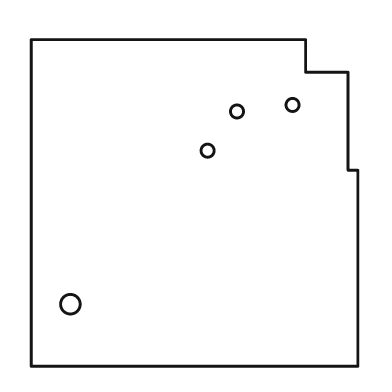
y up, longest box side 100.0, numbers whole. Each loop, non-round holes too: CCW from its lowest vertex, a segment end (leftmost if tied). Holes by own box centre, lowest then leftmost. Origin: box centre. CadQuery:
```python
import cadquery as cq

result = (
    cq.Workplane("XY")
    .moveTo(-50.0, -50.0)
    .lineTo(50.0, -50.0)
    .lineTo(50.0, 10.0)
    .lineTo(47.0, 10.0)
    .lineTo(47.0, 40.0)
    .lineTo(34.0, 40.0)
    .lineTo(34.0, 50.0)
    .lineTo(-50.0, 50.0)
    .close()
    .moveTo(-38.0, -31.0)
    .circle(3.0)
    .moveTo(4.0, 16.0)
    .circle(2.0)
    .moveTo(13.0, 28.0)
    .circle(2.0)
    .moveTo(30.0, 30.0)
    .circle(2.0)
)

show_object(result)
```